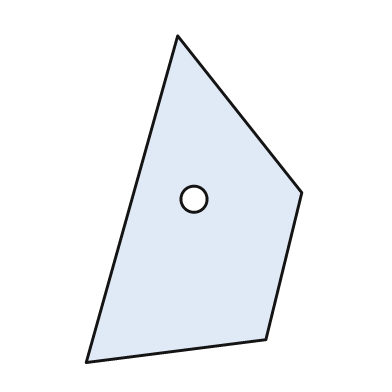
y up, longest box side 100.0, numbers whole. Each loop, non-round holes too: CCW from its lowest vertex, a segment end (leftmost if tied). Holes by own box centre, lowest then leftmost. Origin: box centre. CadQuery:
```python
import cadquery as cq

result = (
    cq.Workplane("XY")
    .moveTo(-33.0, -50.0)
    .lineTo(22.0, -43.0)
    .lineTo(33.0, 2.0)
    .lineTo(-5.0, 50.0)
    .close()
    .moveTo(0.0, 0.0)
    .circle(4.0)
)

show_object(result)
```